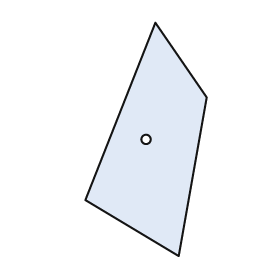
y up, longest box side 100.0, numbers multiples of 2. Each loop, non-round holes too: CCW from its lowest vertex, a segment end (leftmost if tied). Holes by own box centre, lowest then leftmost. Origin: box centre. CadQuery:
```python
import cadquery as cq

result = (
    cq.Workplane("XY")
    .moveTo(14.0, -50.0)
    .lineTo(26.0, 18.0)
    .lineTo(4.0, 50.0)
    .lineTo(-26.0, -26.0)
    .close()
    .moveTo(0.0, 0.0)
    .circle(2.0)
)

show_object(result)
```